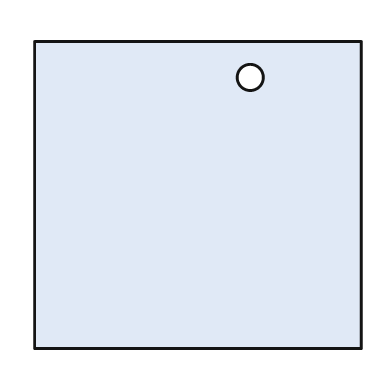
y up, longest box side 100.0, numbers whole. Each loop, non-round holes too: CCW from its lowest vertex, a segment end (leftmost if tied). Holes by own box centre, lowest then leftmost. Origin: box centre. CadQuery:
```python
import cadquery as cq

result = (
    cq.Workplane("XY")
    .moveTo(-50.0, -47.0)
    .lineTo(50.0, -47.0)
    .lineTo(50.0, 47.0)
    .lineTo(-50.0, 47.0)
    .close()
    .moveTo(16.0, 36.0)
    .circle(4.0)
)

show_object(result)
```